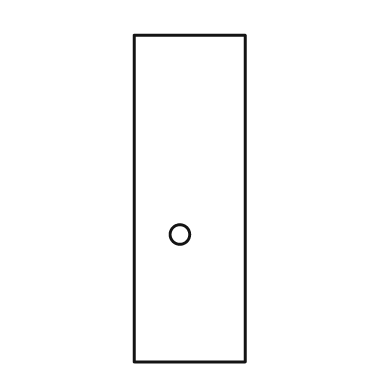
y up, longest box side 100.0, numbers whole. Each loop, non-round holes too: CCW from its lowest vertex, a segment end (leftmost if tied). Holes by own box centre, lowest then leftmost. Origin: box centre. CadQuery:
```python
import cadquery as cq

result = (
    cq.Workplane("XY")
    .moveTo(-17.0, -50.0)
    .lineTo(17.0, -50.0)
    .lineTo(17.0, 50.0)
    .lineTo(-17.0, 50.0)
    .close()
    .moveTo(-3.0, -11.0)
    .circle(3.0)
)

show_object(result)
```